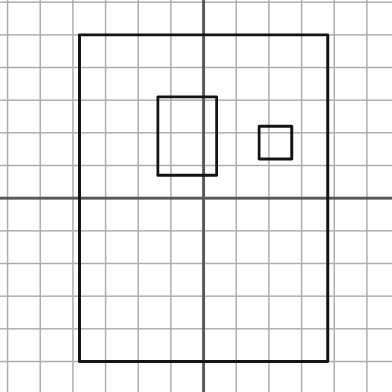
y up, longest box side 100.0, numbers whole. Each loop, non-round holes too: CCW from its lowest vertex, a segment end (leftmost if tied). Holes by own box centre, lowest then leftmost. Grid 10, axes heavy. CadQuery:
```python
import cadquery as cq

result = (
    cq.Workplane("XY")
    .moveTo(-38.0, -50.0)
    .lineTo(38.0, -50.0)
    .lineTo(38.0, 50.0)
    .lineTo(-38.0, 50.0)
    .close()
    .moveTo(17.0, 12.0)
    .lineTo(27.0, 12.0)
    .lineTo(27.0, 22.0)
    .lineTo(17.0, 22.0)
    .close()
    .moveTo(-14.0, 7.0)
    .lineTo(4.0, 7.0)
    .lineTo(4.0, 31.0)
    .lineTo(-14.0, 31.0)
    .close()
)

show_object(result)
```